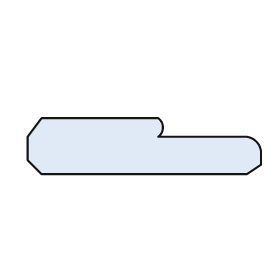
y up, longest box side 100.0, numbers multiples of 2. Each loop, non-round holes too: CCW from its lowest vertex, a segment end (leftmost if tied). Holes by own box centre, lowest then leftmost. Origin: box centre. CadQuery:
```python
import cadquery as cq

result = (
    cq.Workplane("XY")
    .moveTo(-44.0, -12.0)
    .lineTo(44.0, -12.0)
    .lineTo(50.0, -8.0)
    .lineTo(50.0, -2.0)
    .threePointArc((48.0, 2.0), (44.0, 4.0))
    .lineTo(6.0, 4.0)
    .threePointArc((8.0, 8.0), (6.0, 12.0))
    .lineTo(-44.0, 12.0)
    .lineTo(-50.0, 4.0)
    .lineTo(-50.0, -6.0)
    .close()
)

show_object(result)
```